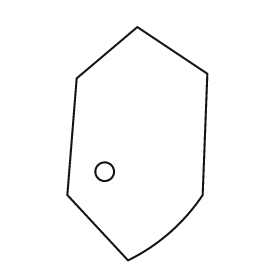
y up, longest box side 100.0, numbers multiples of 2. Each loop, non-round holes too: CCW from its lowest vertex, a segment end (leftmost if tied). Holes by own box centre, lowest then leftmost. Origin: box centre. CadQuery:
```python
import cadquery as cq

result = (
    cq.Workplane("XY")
    .moveTo(-4.0, -50.0)
    .threePointArc((14.0, -38.0), (28.0, -22.0))
    .lineTo(30.0, 30.0)
    .lineTo(0.0, 50.0)
    .lineTo(-26.0, 28.0)
    .lineTo(-30.0, -22.0)
    .close()
    .moveTo(-14.0, -12.0)
    .circle(4.0)
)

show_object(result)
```